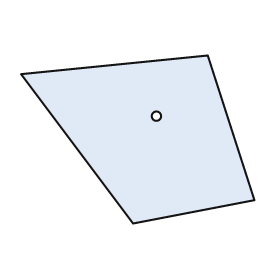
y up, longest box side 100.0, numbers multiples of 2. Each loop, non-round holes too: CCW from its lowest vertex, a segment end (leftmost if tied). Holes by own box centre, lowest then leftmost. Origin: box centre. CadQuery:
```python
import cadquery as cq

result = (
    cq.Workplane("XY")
    .moveTo(-2.0, -36.0)
    .lineTo(50.0, -26.0)
    .lineTo(30.0, 36.0)
    .lineTo(-50.0, 28.0)
    .close()
    .moveTo(8.0, 10.0)
    .circle(2.0)
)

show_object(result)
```